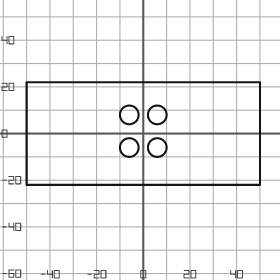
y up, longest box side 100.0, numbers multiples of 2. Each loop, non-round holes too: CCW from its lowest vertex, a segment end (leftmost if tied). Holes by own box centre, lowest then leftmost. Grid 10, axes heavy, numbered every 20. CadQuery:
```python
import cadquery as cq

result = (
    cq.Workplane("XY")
    .moveTo(-50.0, -22.0)
    .lineTo(50.0, -22.0)
    .lineTo(50.0, 22.0)
    .lineTo(-50.0, 22.0)
    .close()
    .moveTo(-6.0, -6.0)
    .circle(4.0)
    .moveTo(6.0, -6.0)
    .circle(4.0)
    .moveTo(-6.0, 8.0)
    .circle(4.0)
    .moveTo(6.0, 8.0)
    .circle(4.0)
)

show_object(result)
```